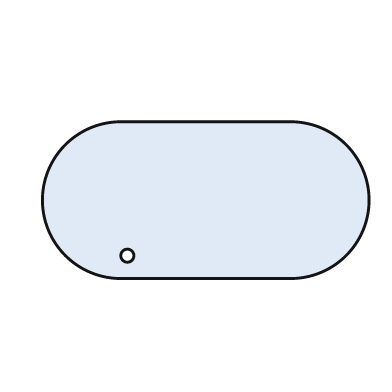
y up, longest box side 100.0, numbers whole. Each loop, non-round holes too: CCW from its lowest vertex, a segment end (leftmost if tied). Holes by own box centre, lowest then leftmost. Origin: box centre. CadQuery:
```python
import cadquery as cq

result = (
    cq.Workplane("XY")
    .moveTo(-26.0, -24.0)
    .lineTo(26.0, -24.0)
    .threePointArc((50.0, 0.0), (26.0, 24.0))
    .lineTo(-26.0, 24.0)
    .threePointArc((-50.0, 0.0), (-26.0, -24.0))
    .close()
    .moveTo(-24.0, -17.0)
    .circle(2.0)
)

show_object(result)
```